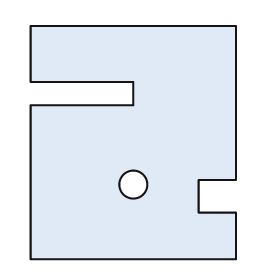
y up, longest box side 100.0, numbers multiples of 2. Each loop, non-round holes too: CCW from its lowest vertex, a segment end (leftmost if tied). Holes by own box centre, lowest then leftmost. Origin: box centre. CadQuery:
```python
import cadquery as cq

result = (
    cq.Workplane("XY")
    .moveTo(-44.0, -50.0)
    .lineTo(44.0, -50.0)
    .lineTo(44.0, -30.0)
    .lineTo(28.0, -30.0)
    .lineTo(28.0, -16.0)
    .lineTo(44.0, -16.0)
    .lineTo(44.0, 50.0)
    .lineTo(-44.0, 50.0)
    .lineTo(-44.0, 26.0)
    .lineTo(0.0, 26.0)
    .lineTo(0.0, 16.0)
    .lineTo(-44.0, 16.0)
    .close()
    .moveTo(0.0, -18.0)
    .circle(6.0)
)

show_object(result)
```